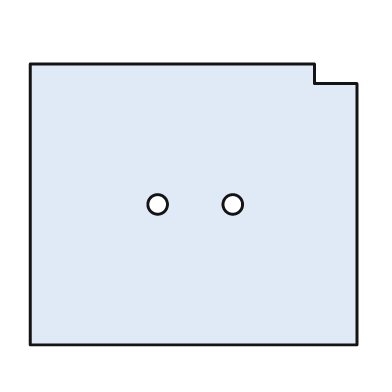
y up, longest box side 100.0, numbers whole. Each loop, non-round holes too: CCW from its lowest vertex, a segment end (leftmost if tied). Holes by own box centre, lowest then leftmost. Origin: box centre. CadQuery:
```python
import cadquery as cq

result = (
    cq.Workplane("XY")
    .moveTo(-50.0, -43.0)
    .lineTo(50.0, -43.0)
    .lineTo(50.0, 37.0)
    .lineTo(37.0, 37.0)
    .lineTo(37.0, 43.0)
    .lineTo(-50.0, 43.0)
    .close()
    .moveTo(-11.0, 0.0)
    .circle(3.0)
    .moveTo(12.0, 0.0)
    .circle(3.0)
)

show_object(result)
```